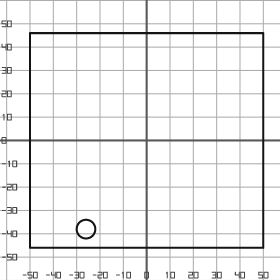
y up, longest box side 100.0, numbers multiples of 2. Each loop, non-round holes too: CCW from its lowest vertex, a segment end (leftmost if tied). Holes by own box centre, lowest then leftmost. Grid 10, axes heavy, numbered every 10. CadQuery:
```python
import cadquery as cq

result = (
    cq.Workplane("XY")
    .moveTo(-50.0, -46.0)
    .lineTo(50.0, -46.0)
    .lineTo(50.0, 46.0)
    .lineTo(-50.0, 46.0)
    .close()
    .moveTo(-26.0, -38.0)
    .circle(4.0)
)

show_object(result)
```